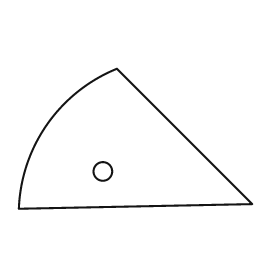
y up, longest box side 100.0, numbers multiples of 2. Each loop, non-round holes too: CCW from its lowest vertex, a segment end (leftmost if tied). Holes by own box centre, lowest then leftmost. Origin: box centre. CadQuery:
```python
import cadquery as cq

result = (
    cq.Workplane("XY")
    .moveTo(-50.0, -30.0)
    .lineTo(50.0, -28.0)
    .lineTo(-8.0, 30.0)
    .threePointArc((-38.0, 6.0), (-50.0, -30.0))
    .close()
    .moveTo(-14.0, -14.0)
    .circle(4.0)
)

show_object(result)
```